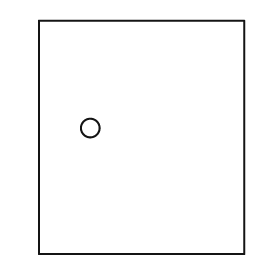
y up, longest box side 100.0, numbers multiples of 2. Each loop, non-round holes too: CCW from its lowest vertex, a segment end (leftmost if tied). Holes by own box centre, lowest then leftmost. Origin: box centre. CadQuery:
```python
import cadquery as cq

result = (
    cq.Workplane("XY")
    .moveTo(-44.0, -50.0)
    .lineTo(44.0, -50.0)
    .lineTo(44.0, 50.0)
    .lineTo(-44.0, 50.0)
    .close()
    .moveTo(-22.0, 4.0)
    .circle(4.0)
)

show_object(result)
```